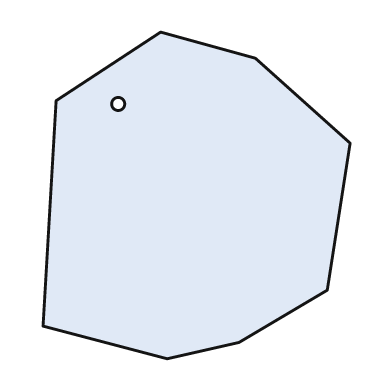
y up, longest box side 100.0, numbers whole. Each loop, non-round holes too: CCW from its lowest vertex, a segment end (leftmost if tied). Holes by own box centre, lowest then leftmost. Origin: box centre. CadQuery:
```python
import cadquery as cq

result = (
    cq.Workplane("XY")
    .moveTo(-9.0, -50.0)
    .lineTo(13.0, -45.0)
    .lineTo(40.0, -29.0)
    .lineTo(47.0, 16.0)
    .lineTo(18.0, 42.0)
    .lineTo(-11.0, 50.0)
    .lineTo(-43.0, 29.0)
    .lineTo(-47.0, -40.0)
    .close()
    .moveTo(-24.0, 28.0)
    .circle(2.0)
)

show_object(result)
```